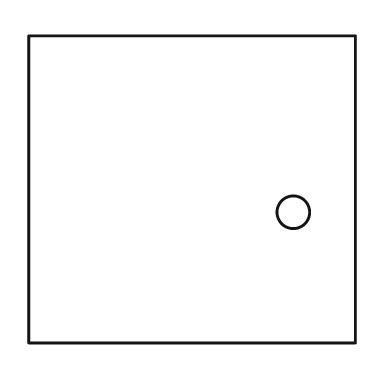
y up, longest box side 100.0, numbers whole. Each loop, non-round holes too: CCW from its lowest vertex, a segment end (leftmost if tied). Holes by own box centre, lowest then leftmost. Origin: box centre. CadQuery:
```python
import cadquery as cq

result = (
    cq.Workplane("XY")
    .moveTo(-50.0, -47.0)
    .lineTo(50.0, -47.0)
    .lineTo(50.0, 47.0)
    .lineTo(-50.0, 47.0)
    .close()
    .moveTo(31.0, -7.0)
    .circle(5.0)
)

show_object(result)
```